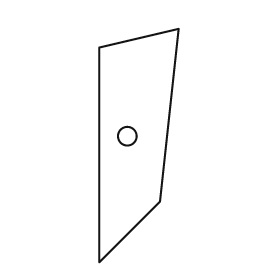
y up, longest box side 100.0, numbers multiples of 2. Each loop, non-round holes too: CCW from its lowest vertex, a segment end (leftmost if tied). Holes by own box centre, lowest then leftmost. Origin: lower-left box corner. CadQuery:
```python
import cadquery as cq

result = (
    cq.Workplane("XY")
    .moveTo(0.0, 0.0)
    .lineTo(26.0, 26.0)
    .lineTo(34.0, 100.0)
    .lineTo(0.0, 92.0)
    .close()
    .moveTo(12.0, 54.0)
    .circle(4.0)
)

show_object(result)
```